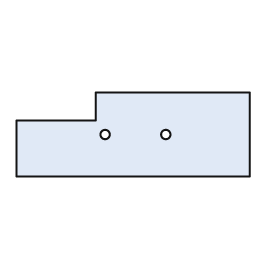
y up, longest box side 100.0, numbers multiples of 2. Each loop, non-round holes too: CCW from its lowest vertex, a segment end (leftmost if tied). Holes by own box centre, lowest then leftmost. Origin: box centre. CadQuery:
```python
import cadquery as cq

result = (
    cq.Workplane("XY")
    .moveTo(-50.0, -18.0)
    .lineTo(50.0, -18.0)
    .lineTo(50.0, 18.0)
    .lineTo(-16.0, 18.0)
    .lineTo(-16.0, 6.0)
    .lineTo(-50.0, 6.0)
    .close()
    .moveTo(-12.0, 0.0)
    .circle(2.0)
    .moveTo(14.0, 0.0)
    .circle(2.0)
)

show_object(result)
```